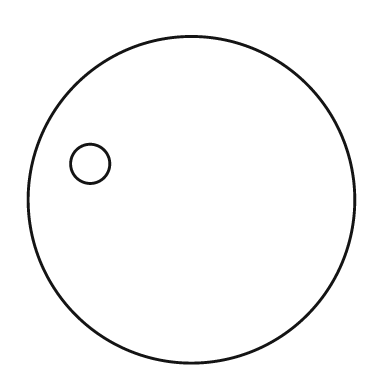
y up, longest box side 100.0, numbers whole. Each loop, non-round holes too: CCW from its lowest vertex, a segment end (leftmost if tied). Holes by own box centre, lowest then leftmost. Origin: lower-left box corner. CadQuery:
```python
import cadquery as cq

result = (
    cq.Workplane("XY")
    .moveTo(50.0, 50.0)
    .circle(50.0)
    .moveTo(19.0, 61.0)
    .circle(6.0)
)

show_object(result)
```